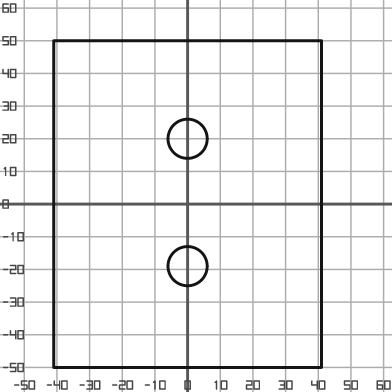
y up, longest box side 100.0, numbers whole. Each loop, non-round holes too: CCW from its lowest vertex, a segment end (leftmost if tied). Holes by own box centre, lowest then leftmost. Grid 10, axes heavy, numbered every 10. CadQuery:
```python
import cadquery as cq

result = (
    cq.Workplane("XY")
    .moveTo(-41.0, -50.0)
    .lineTo(41.0, -50.0)
    .lineTo(41.0, 50.0)
    .lineTo(-41.0, 50.0)
    .close()
    .moveTo(0.0, -19.0)
    .circle(6.0)
    .moveTo(0.0, 20.0)
    .circle(6.0)
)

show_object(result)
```